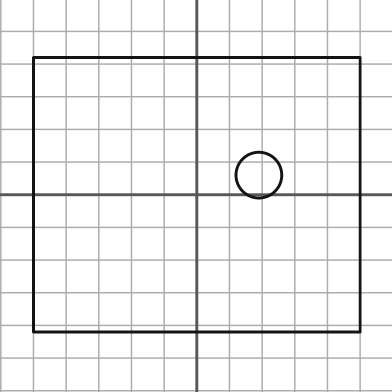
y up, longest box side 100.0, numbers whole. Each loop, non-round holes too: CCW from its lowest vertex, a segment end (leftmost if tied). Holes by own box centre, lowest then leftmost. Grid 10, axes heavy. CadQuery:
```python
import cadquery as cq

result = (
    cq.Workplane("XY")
    .moveTo(-50.0, -42.0)
    .lineTo(50.0, -42.0)
    .lineTo(50.0, 42.0)
    .lineTo(-50.0, 42.0)
    .close()
    .moveTo(19.0, 6.0)
    .circle(7.0)
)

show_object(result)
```